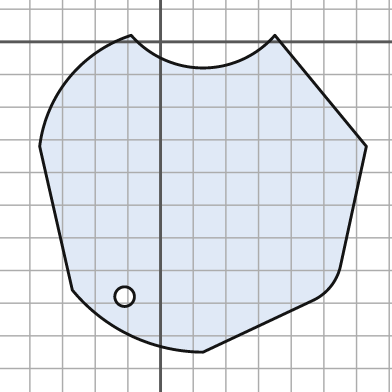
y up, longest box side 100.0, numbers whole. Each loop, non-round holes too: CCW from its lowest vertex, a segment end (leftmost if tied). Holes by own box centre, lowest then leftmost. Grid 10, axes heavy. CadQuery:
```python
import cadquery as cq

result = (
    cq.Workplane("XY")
    .moveTo(13.0, -95.0)
    .lineTo(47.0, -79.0)
    .threePointArc((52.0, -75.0), (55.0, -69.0))
    .lineTo(63.0, -32.0)
    .lineTo(35.0, 2.0)
    .threePointArc((13.0, -8.0), (-9.0, 2.0))
    .threePointArc((-28.0, -11.0), (-37.0, -32.0))
    .lineTo(-27.0, -76.0)
    .threePointArc((-9.0, -90.0), (13.0, -95.0))
    .close()
    .moveTo(-11.0, -78.0)
    .circle(3.0)
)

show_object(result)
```